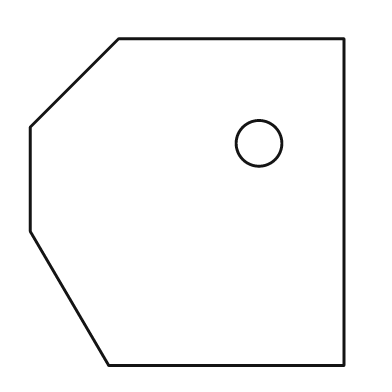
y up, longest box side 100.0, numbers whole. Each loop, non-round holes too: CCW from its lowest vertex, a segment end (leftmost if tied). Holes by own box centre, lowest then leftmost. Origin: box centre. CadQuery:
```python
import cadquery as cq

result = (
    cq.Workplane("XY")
    .moveTo(-24.0, -50.0)
    .lineTo(48.0, -50.0)
    .lineTo(48.0, 50.0)
    .lineTo(-21.0, 50.0)
    .lineTo(-48.0, 23.0)
    .lineTo(-48.0, -9.0)
    .close()
    .moveTo(22.0, 18.0)
    .circle(7.0)
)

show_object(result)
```